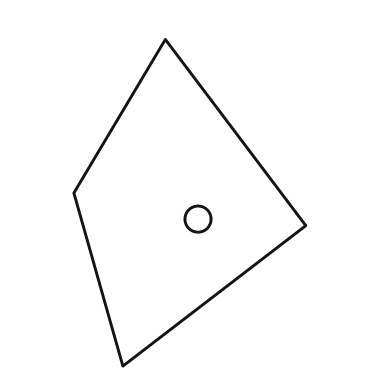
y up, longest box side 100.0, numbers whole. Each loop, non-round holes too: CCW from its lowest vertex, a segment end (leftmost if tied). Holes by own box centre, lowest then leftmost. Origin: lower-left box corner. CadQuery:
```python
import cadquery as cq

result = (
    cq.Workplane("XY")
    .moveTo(15.0, 0.0)
    .lineTo(71.0, 43.0)
    .lineTo(28.0, 100.0)
    .lineTo(0.0, 53.0)
    .close()
    .moveTo(38.0, 45.0)
    .circle(4.0)
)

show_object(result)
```